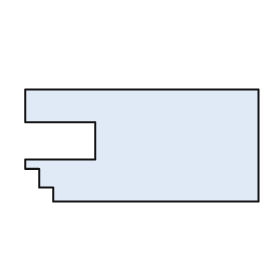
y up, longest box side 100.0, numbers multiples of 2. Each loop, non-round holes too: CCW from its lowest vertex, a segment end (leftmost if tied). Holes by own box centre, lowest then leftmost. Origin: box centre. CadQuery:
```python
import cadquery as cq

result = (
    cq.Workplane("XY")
    .moveTo(-38.0, -24.0)
    .lineTo(50.0, -24.0)
    .lineTo(50.0, 24.0)
    .lineTo(-50.0, 24.0)
    .lineTo(-50.0, 10.0)
    .lineTo(-20.0, 10.0)
    .lineTo(-20.0, -6.0)
    .lineTo(-50.0, -6.0)
    .lineTo(-50.0, -10.0)
    .lineTo(-44.0, -10.0)
    .lineTo(-44.0, -18.0)
    .lineTo(-38.0, -18.0)
    .close()
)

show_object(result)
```